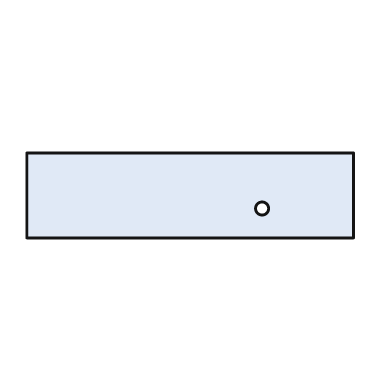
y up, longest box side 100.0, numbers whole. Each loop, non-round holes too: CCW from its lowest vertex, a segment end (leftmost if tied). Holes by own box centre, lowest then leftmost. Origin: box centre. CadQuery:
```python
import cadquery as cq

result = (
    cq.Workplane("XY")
    .moveTo(-50.0, -13.0)
    .lineTo(50.0, -13.0)
    .lineTo(50.0, 13.0)
    .lineTo(-50.0, 13.0)
    .close()
    .moveTo(22.0, -4.0)
    .circle(2.0)
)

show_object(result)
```